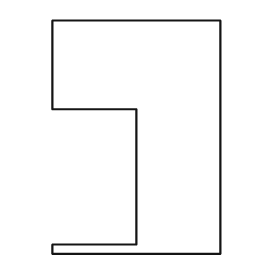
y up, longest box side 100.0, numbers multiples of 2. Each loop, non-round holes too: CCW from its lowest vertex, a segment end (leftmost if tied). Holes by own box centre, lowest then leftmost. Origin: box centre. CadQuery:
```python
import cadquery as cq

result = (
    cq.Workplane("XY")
    .moveTo(-36.0, -50.0)
    .lineTo(36.0, -50.0)
    .lineTo(36.0, 50.0)
    .lineTo(-36.0, 50.0)
    .lineTo(-36.0, 12.0)
    .lineTo(0.0, 12.0)
    .lineTo(0.0, -46.0)
    .lineTo(-36.0, -46.0)
    .close()
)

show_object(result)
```